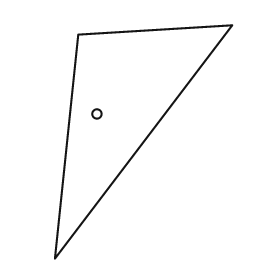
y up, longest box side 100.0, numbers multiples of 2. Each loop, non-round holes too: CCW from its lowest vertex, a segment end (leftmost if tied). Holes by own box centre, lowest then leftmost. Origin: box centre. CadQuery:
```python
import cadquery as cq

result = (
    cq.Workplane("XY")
    .moveTo(-38.0, -50.0)
    .lineTo(38.0, 50.0)
    .lineTo(-28.0, 46.0)
    .close()
    .moveTo(-20.0, 12.0)
    .circle(2.0)
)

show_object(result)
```